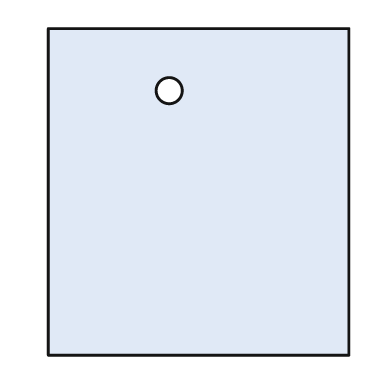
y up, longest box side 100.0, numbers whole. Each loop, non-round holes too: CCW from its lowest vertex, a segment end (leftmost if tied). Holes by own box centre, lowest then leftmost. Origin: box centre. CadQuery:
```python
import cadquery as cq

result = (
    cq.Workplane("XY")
    .moveTo(-46.0, -50.0)
    .lineTo(46.0, -50.0)
    .lineTo(46.0, 50.0)
    .lineTo(-46.0, 50.0)
    .close()
    .moveTo(-9.0, 31.0)
    .circle(4.0)
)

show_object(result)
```